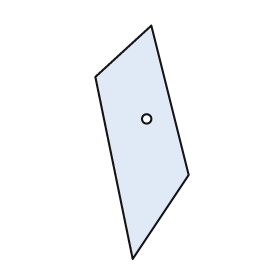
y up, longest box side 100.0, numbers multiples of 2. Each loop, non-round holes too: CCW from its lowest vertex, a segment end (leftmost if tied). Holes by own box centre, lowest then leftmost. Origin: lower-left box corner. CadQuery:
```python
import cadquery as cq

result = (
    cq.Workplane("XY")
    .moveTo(16.0, 0.0)
    .lineTo(40.0, 36.0)
    .lineTo(24.0, 100.0)
    .lineTo(0.0, 78.0)
    .close()
    .moveTo(22.0, 60.0)
    .circle(2.0)
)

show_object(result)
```